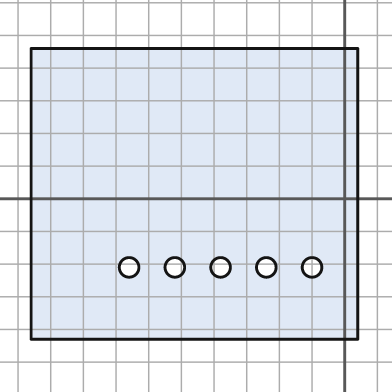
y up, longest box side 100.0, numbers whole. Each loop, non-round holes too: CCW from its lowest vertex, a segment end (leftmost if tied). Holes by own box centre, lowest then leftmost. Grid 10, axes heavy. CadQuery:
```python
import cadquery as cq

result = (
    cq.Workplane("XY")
    .moveTo(-96.0, -43.0)
    .lineTo(4.0, -43.0)
    .lineTo(4.0, 46.0)
    .lineTo(-96.0, 46.0)
    .close()
    .moveTo(-66.0, -21.0)
    .circle(3.0)
    .moveTo(-52.0, -21.0)
    .circle(3.0)
    .moveTo(-38.0, -21.0)
    .circle(3.0)
    .moveTo(-24.0, -21.0)
    .circle(3.0)
    .moveTo(-10.0, -21.0)
    .circle(3.0)
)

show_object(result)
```